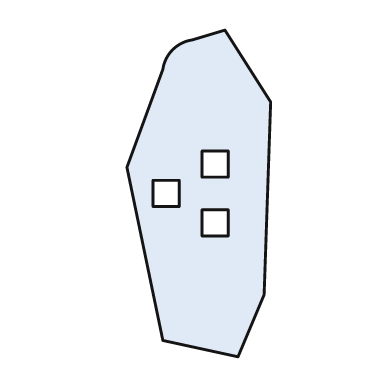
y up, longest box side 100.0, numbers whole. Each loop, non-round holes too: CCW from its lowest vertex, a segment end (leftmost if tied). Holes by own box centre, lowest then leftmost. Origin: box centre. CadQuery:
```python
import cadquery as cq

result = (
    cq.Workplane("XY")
    .moveTo(12.0, -50.0)
    .lineTo(20.0, -31.0)
    .lineTo(22.0, 28.0)
    .lineTo(8.0, 50.0)
    .lineTo(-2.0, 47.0)
    .threePointArc((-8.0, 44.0), (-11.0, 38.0))
    .lineTo(-22.0, 8.0)
    .lineTo(-11.0, -45.0)
    .close()
    .moveTo(1.0, -13.0)
    .lineTo(9.0, -13.0)
    .lineTo(9.0, -5.0)
    .lineTo(1.0, -5.0)
    .close()
    .moveTo(-14.0, -4.0)
    .lineTo(-6.0, -4.0)
    .lineTo(-6.0, 4.0)
    .lineTo(-14.0, 4.0)
    .close()
    .moveTo(1.0, 5.0)
    .lineTo(9.0, 5.0)
    .lineTo(9.0, 13.0)
    .lineTo(1.0, 13.0)
    .close()
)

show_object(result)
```